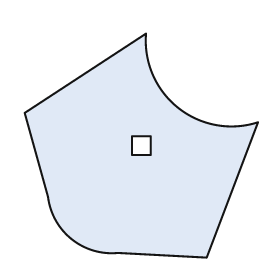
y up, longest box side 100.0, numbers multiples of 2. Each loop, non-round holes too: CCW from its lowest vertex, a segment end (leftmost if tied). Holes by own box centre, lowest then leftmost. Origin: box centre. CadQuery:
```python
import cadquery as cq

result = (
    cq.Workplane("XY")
    .moveTo(28.0, -48.0)
    .lineTo(50.0, 10.0)
    .threePointArc((16.0, 16.0), (2.0, 48.0))
    .lineTo(-50.0, 14.0)
    .lineTo(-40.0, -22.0)
    .threePointArc((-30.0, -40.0), (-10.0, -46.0))
    .close()
    .moveTo(-4.0, -4.0)
    .lineTo(4.0, -4.0)
    .lineTo(4.0, 4.0)
    .lineTo(-4.0, 4.0)
    .close()
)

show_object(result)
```